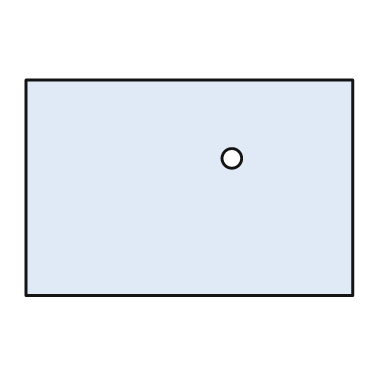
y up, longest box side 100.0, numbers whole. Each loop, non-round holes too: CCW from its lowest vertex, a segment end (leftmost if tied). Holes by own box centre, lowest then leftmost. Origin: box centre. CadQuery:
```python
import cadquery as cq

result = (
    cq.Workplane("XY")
    .moveTo(-50.0, -33.0)
    .lineTo(50.0, -33.0)
    .lineTo(50.0, 33.0)
    .lineTo(-50.0, 33.0)
    .close()
    .moveTo(13.0, 9.0)
    .circle(3.0)
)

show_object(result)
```